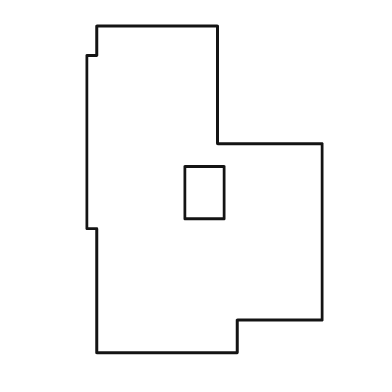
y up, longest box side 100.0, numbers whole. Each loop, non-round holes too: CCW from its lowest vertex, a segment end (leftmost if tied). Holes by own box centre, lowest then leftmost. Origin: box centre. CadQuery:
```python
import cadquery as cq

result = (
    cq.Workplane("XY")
    .moveTo(-33.0, -50.0)
    .lineTo(10.0, -50.0)
    .lineTo(10.0, -40.0)
    .lineTo(36.0, -40.0)
    .lineTo(36.0, 14.0)
    .lineTo(4.0, 14.0)
    .lineTo(4.0, 50.0)
    .lineTo(-33.0, 50.0)
    .lineTo(-33.0, 41.0)
    .lineTo(-36.0, 41.0)
    .lineTo(-36.0, -12.0)
    .lineTo(-33.0, -12.0)
    .close()
    .moveTo(-6.0, -9.0)
    .lineTo(6.0, -9.0)
    .lineTo(6.0, 7.0)
    .lineTo(-6.0, 7.0)
    .close()
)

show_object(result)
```